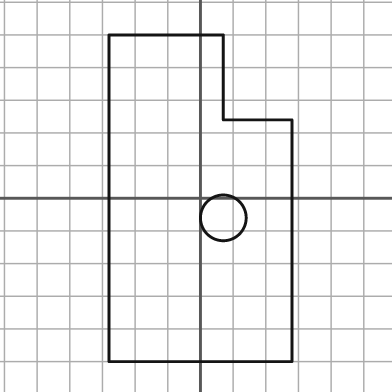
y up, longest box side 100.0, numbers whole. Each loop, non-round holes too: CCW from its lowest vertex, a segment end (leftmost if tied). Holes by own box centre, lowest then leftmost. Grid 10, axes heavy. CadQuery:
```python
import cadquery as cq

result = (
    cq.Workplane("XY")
    .moveTo(-28.0, -50.0)
    .lineTo(28.0, -50.0)
    .lineTo(28.0, 24.0)
    .lineTo(7.0, 24.0)
    .lineTo(7.0, 50.0)
    .lineTo(-28.0, 50.0)
    .close()
    .moveTo(7.0, -6.0)
    .circle(7.0)
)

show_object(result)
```